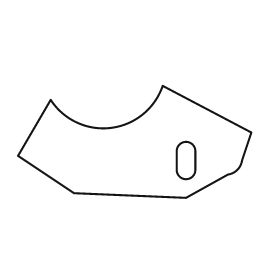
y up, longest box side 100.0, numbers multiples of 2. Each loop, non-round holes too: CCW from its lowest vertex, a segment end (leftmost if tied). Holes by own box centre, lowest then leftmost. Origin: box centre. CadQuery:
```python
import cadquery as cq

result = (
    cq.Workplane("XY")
    .moveTo(22.0, -24.0)
    .lineTo(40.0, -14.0)
    .threePointArc((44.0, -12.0), (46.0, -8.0))
    .lineTo(50.0, 4.0)
    .lineTo(12.0, 24.0)
    .threePointArc((-10.0, 6.0), (-36.0, 18.0))
    .lineTo(-50.0, -6.0)
    .lineTo(-26.0, -22.0)
    .close()
    .moveTo(18.0, -12.0)
    .threePointArc((22.0, -16.0), (26.0, -12.0))
    .lineTo(26.0, -4.0)
    .threePointArc((22.0, 0.0), (18.0, -4.0))
    .close()
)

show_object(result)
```